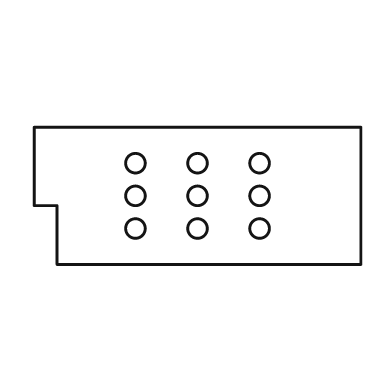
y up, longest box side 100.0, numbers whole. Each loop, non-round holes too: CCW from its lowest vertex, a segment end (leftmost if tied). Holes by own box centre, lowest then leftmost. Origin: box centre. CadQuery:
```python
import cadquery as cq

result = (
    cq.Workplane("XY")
    .moveTo(-43.0, -21.0)
    .lineTo(50.0, -21.0)
    .lineTo(50.0, 21.0)
    .lineTo(-50.0, 21.0)
    .lineTo(-50.0, -3.0)
    .lineTo(-43.0, -3.0)
    .close()
    .moveTo(-19.0, -10.0)
    .circle(3.0)
    .moveTo(0.0, -10.0)
    .circle(3.0)
    .moveTo(19.0, -10.0)
    .circle(3.0)
    .moveTo(-19.0, 0.0)
    .circle(3.0)
    .moveTo(0.0, 0.0)
    .circle(3.0)
    .moveTo(19.0, 0.0)
    .circle(3.0)
    .moveTo(-19.0, 10.0)
    .circle(3.0)
    .moveTo(0.0, 10.0)
    .circle(3.0)
    .moveTo(19.0, 10.0)
    .circle(3.0)
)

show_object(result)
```